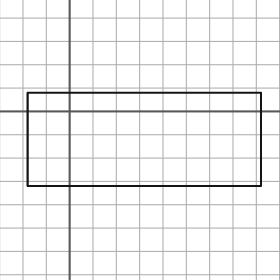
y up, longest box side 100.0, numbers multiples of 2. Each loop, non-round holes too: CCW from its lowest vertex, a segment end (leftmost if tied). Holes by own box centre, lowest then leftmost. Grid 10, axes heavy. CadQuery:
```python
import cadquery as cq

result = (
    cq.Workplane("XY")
    .moveTo(-18.0, -32.0)
    .lineTo(82.0, -32.0)
    .lineTo(82.0, 8.0)
    .lineTo(-18.0, 8.0)
    .close()
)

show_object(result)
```